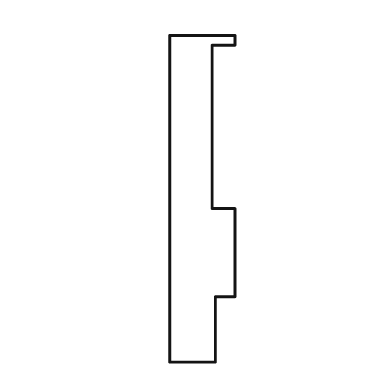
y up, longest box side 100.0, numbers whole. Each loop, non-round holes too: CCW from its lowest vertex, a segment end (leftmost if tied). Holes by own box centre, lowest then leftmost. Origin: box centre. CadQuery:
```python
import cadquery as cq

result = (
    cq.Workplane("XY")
    .moveTo(-10.0, -50.0)
    .lineTo(4.0, -50.0)
    .lineTo(4.0, -30.0)
    .lineTo(10.0, -30.0)
    .lineTo(10.0, -3.0)
    .lineTo(3.0, -3.0)
    .lineTo(3.0, 47.0)
    .lineTo(10.0, 47.0)
    .lineTo(10.0, 50.0)
    .lineTo(-10.0, 50.0)
    .close()
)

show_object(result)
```